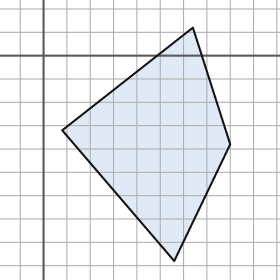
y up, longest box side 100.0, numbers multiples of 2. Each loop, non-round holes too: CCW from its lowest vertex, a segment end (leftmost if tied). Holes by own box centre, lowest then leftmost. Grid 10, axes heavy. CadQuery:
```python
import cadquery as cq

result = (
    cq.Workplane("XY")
    .moveTo(56.0, -88.0)
    .lineTo(80.0, -38.0)
    .lineTo(64.0, 12.0)
    .lineTo(8.0, -32.0)
    .close()
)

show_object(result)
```